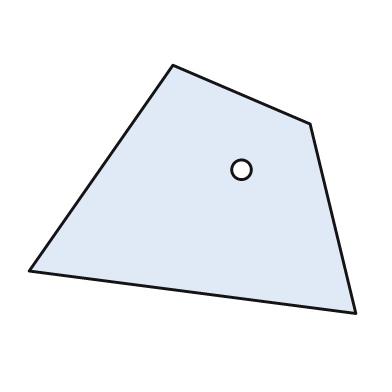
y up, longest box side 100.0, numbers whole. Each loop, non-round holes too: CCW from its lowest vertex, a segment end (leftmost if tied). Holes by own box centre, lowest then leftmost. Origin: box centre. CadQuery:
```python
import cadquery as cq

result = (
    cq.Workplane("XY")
    .moveTo(50.0, -38.0)
    .lineTo(36.0, 20.0)
    .lineTo(-6.0, 38.0)
    .lineTo(-50.0, -25.0)
    .close()
    .moveTo(15.0, 6.0)
    .circle(3.0)
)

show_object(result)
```